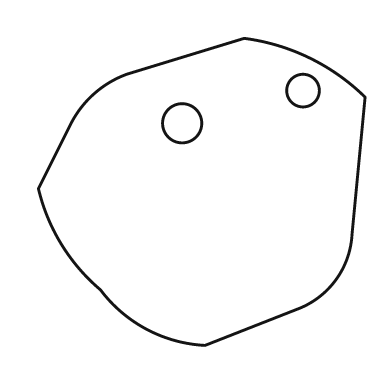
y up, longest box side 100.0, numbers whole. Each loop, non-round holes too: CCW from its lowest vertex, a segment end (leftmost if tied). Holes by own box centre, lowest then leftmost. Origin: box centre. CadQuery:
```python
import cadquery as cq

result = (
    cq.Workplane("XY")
    .moveTo(1.0, -47.0)
    .lineTo(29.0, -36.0)
    .threePointArc((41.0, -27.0), (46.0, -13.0))
    .lineTo(50.0, 29.0)
    .threePointArc((33.0, 41.0), (13.0, 47.0))
    .lineTo(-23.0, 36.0)
    .threePointArc((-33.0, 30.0), (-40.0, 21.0))
    .lineTo(-50.0, 1.0)
    .threePointArc((-43.0, -16.0), (-31.0, -30.0))
    .threePointArc((-17.0, -42.0), (1.0, -47.0))
    .close()
    .moveTo(-6.0, 21.0)
    .circle(6.0)
    .moveTo(31.0, 31.0)
    .circle(5.0)
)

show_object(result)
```